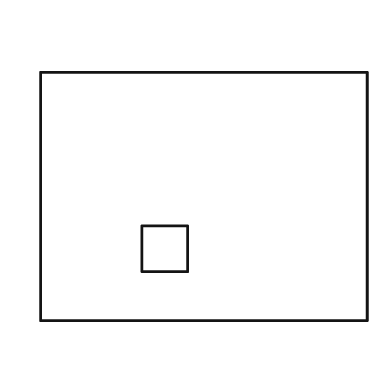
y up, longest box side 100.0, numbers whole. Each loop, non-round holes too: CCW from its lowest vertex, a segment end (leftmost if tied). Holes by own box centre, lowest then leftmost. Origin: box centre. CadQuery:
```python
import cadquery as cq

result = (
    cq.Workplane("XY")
    .moveTo(-50.0, -38.0)
    .lineTo(50.0, -38.0)
    .lineTo(50.0, 38.0)
    .lineTo(-50.0, 38.0)
    .close()
    .moveTo(-19.0, -23.0)
    .lineTo(-5.0, -23.0)
    .lineTo(-5.0, -9.0)
    .lineTo(-19.0, -9.0)
    .close()
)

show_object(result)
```